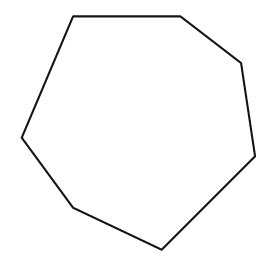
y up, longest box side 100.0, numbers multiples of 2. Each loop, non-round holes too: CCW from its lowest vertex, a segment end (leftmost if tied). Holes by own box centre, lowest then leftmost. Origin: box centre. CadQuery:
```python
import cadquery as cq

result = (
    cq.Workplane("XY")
    .moveTo(10.0, -50.0)
    .lineTo(50.0, -10.0)
    .lineTo(44.0, 30.0)
    .lineTo(18.0, 50.0)
    .lineTo(-28.0, 50.0)
    .lineTo(-50.0, -2.0)
    .lineTo(-28.0, -32.0)
    .close()
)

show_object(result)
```